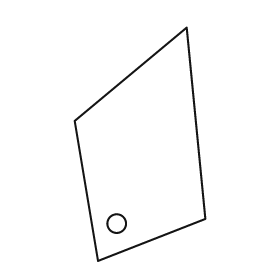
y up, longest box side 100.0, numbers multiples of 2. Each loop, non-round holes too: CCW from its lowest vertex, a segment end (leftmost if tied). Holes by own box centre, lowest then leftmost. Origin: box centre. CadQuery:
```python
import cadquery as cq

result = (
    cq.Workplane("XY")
    .moveTo(-18.0, -50.0)
    .lineTo(28.0, -32.0)
    .lineTo(20.0, 50.0)
    .lineTo(-28.0, 10.0)
    .close()
    .moveTo(-10.0, -34.0)
    .circle(4.0)
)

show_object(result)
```